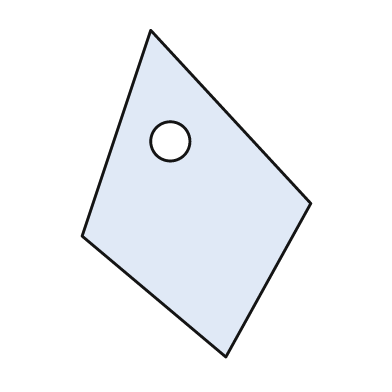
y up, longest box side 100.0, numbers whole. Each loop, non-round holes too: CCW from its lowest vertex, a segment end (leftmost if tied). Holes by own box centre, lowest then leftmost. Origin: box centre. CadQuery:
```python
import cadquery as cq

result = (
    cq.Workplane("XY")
    .moveTo(9.0, -50.0)
    .lineTo(35.0, -3.0)
    .lineTo(-14.0, 50.0)
    .lineTo(-35.0, -13.0)
    .close()
    .moveTo(-8.0, 16.0)
    .circle(6.0)
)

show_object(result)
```